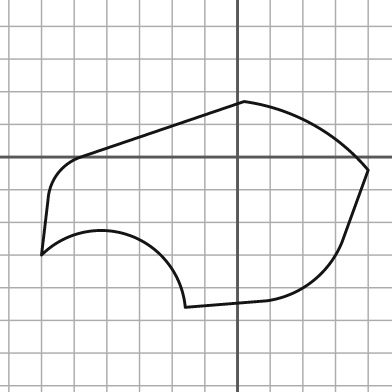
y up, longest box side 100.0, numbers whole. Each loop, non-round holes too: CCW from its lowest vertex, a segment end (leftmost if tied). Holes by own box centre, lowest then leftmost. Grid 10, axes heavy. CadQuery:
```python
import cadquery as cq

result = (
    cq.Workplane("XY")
    .moveTo(-16.0, -46.0)
    .lineTo(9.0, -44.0)
    .threePointArc((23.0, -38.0), (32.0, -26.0))
    .lineTo(40.0, -4.0)
    .threePointArc((23.0, 10.0), (2.0, 17.0))
    .lineTo(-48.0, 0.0)
    .threePointArc((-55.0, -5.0), (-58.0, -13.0))
    .lineTo(-60.0, -30.0)
    .threePointArc((-33.0, -24.0), (-16.0, -46.0))
    .close()
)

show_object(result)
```